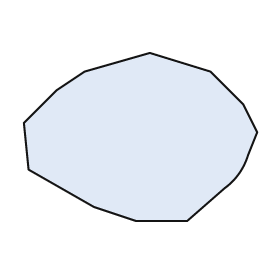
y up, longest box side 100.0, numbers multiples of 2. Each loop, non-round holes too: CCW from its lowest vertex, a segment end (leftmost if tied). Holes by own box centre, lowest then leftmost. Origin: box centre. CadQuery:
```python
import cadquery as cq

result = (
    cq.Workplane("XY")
    .moveTo(-2.0, -36.0)
    .lineTo(20.0, -36.0)
    .lineTo(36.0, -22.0)
    .threePointArc((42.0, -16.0), (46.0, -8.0))
    .lineTo(50.0, 2.0)
    .lineTo(44.0, 14.0)
    .lineTo(30.0, 28.0)
    .lineTo(4.0, 36.0)
    .lineTo(-24.0, 28.0)
    .lineTo(-36.0, 20.0)
    .lineTo(-50.0, 6.0)
    .lineTo(-48.0, -14.0)
    .lineTo(-20.0, -30.0)
    .close()
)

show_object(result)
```